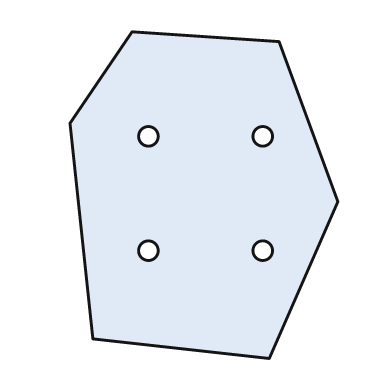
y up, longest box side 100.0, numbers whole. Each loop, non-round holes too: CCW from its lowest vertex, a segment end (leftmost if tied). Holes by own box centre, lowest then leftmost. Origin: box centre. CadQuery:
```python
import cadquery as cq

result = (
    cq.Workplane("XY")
    .moveTo(20.0, -50.0)
    .lineTo(41.0, -2.0)
    .lineTo(23.0, 47.0)
    .lineTo(-22.0, 50.0)
    .lineTo(-41.0, 22.0)
    .lineTo(-34.0, -44.0)
    .close()
    .moveTo(-17.0, -17.0)
    .circle(3.0)
    .moveTo(18.0, -17.0)
    .circle(3.0)
    .moveTo(-17.0, 18.0)
    .circle(3.0)
    .moveTo(18.0, 18.0)
    .circle(3.0)
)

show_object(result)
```